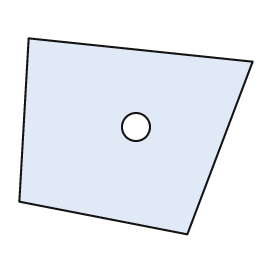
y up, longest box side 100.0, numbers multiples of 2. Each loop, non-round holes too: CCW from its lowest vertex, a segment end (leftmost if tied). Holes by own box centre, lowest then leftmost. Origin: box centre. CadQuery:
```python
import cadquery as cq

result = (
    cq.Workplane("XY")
    .moveTo(22.0, -42.0)
    .lineTo(50.0, 32.0)
    .lineTo(-46.0, 42.0)
    .lineTo(-50.0, -28.0)
    .close()
    .moveTo(0.0, 4.0)
    .circle(6.0)
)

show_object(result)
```